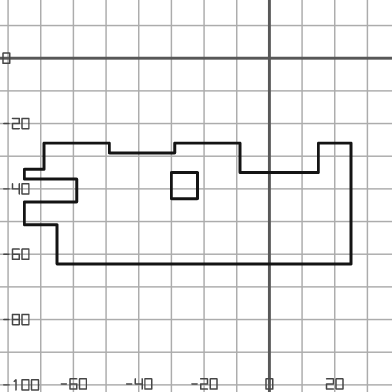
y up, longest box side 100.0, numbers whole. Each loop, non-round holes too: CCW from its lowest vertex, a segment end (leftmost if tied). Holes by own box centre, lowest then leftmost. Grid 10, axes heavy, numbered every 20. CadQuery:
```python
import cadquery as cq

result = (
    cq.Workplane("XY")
    .moveTo(-65.0, -63.0)
    .lineTo(25.0, -63.0)
    .lineTo(25.0, -26.0)
    .lineTo(15.0, -26.0)
    .lineTo(15.0, -35.0)
    .lineTo(-9.0, -35.0)
    .lineTo(-9.0, -26.0)
    .lineTo(-29.0, -26.0)
    .lineTo(-29.0, -29.0)
    .lineTo(-49.0, -29.0)
    .lineTo(-49.0, -26.0)
    .lineTo(-69.0, -26.0)
    .lineTo(-69.0, -34.0)
    .lineTo(-75.0, -34.0)
    .lineTo(-75.0, -37.0)
    .lineTo(-59.0, -37.0)
    .lineTo(-59.0, -44.0)
    .lineTo(-75.0, -44.0)
    .lineTo(-75.0, -51.0)
    .lineTo(-65.0, -51.0)
    .close()
    .moveTo(-30.0, -43.0)
    .lineTo(-22.0, -43.0)
    .lineTo(-22.0, -35.0)
    .lineTo(-30.0, -35.0)
    .close()
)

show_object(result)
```